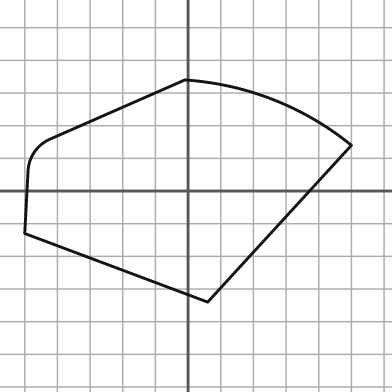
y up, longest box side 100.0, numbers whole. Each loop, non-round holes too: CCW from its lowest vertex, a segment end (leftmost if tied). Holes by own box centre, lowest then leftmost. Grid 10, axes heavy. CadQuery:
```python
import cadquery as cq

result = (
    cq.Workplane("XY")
    .moveTo(6.0, -34.0)
    .lineTo(50.0, 14.0)
    .threePointArc((26.0, 28.0), (-1.0, 34.0))
    .lineTo(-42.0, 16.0)
    .threePointArc((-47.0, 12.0), (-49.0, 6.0))
    .lineTo(-50.0, -13.0)
    .close()
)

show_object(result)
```